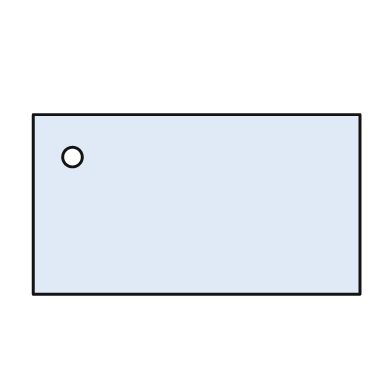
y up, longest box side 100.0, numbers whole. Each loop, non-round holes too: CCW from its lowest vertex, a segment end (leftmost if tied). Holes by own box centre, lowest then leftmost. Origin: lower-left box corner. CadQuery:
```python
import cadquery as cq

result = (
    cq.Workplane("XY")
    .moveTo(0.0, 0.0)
    .lineTo(100.0, 0.0)
    .lineTo(100.0, 55.0)
    .lineTo(0.0, 55.0)
    .close()
    .moveTo(12.0, 42.0)
    .circle(3.0)
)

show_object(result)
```